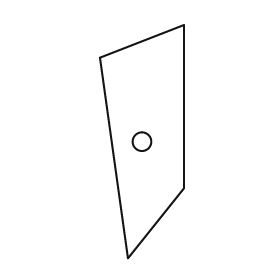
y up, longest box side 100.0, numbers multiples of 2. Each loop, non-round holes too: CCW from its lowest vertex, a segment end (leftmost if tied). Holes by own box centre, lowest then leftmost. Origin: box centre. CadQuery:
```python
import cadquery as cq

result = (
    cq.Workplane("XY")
    .moveTo(-6.0, -50.0)
    .lineTo(18.0, -20.0)
    .lineTo(18.0, 50.0)
    .lineTo(-18.0, 36.0)
    .close()
    .moveTo(0.0, 0.0)
    .circle(4.0)
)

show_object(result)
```